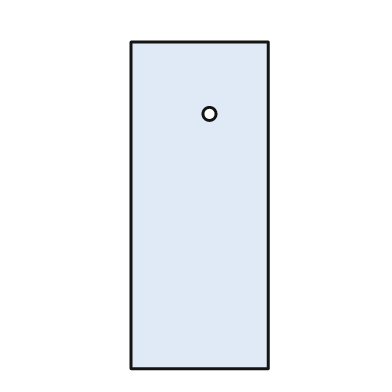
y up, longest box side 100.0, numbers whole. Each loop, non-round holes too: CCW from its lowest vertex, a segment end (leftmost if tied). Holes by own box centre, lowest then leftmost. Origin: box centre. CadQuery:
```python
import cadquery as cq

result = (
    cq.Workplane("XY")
    .moveTo(-21.0, -50.0)
    .lineTo(21.0, -50.0)
    .lineTo(21.0, 50.0)
    .lineTo(-21.0, 50.0)
    .close()
    .moveTo(3.0, 28.0)
    .circle(2.0)
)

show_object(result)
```